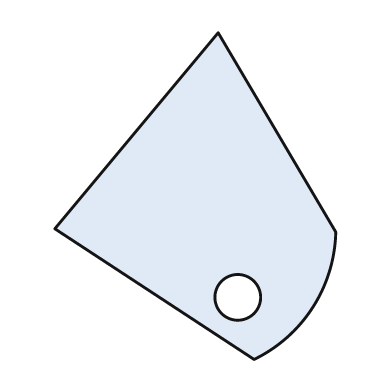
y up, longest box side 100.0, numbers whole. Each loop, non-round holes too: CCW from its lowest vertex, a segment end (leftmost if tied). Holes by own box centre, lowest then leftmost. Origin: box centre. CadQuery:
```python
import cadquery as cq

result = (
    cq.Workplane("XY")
    .moveTo(18.0, -50.0)
    .threePointArc((36.0, -34.0), (43.0, -11.0))
    .lineTo(7.0, 50.0)
    .lineTo(-43.0, -10.0)
    .close()
    .moveTo(13.0, -31.0)
    .circle(7.0)
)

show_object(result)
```